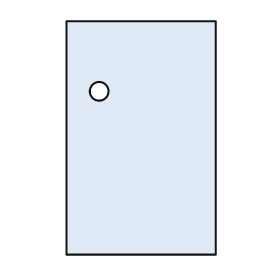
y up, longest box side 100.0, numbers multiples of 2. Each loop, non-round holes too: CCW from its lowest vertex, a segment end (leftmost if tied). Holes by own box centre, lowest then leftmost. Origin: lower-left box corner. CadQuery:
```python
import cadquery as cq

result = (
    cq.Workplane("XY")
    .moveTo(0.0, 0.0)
    .lineTo(64.0, 0.0)
    .lineTo(64.0, 100.0)
    .lineTo(0.0, 100.0)
    .close()
    .moveTo(14.0, 70.0)
    .circle(4.0)
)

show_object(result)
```